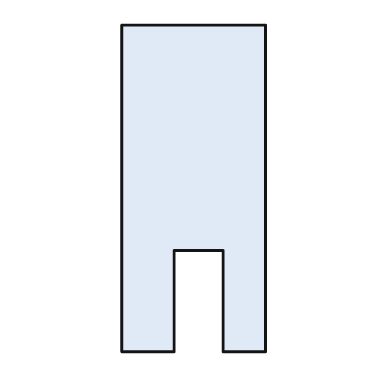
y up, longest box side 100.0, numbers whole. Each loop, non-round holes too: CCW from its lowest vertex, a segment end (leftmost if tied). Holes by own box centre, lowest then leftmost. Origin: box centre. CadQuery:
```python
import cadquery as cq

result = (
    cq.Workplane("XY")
    .moveTo(-22.0, -50.0)
    .lineTo(-6.0, -50.0)
    .lineTo(-6.0, -19.0)
    .lineTo(9.0, -19.0)
    .lineTo(9.0, -50.0)
    .lineTo(22.0, -50.0)
    .lineTo(22.0, 50.0)
    .lineTo(-22.0, 50.0)
    .close()
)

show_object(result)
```